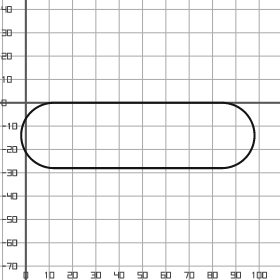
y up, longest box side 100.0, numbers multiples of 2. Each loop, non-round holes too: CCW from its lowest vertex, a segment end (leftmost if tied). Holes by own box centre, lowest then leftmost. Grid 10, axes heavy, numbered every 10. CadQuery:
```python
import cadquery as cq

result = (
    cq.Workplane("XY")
    .moveTo(12.0, -28.0)
    .lineTo(84.0, -28.0)
    .threePointArc((98.0, -14.0), (84.0, 0.0))
    .lineTo(12.0, 0.0)
    .threePointArc((-2.0, -14.0), (12.0, -28.0))
    .close()
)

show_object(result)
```